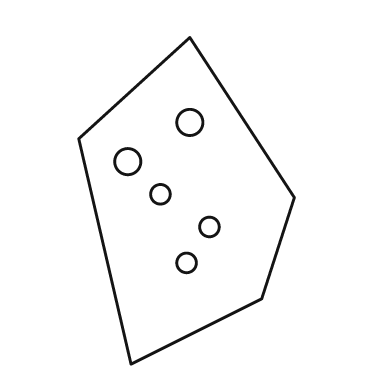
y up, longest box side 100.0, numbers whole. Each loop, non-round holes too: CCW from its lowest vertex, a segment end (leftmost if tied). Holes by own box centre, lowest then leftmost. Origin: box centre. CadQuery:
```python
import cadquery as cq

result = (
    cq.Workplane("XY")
    .moveTo(-17.0, -50.0)
    .lineTo(23.0, -30.0)
    .lineTo(33.0, 1.0)
    .lineTo(1.0, 50.0)
    .lineTo(-33.0, 19.0)
    .close()
    .moveTo(0.0, -19.0)
    .circle(3.0)
    .moveTo(7.0, -8.0)
    .circle(3.0)
    .moveTo(-8.0, 2.0)
    .circle(3.0)
    .moveTo(-18.0, 12.0)
    .circle(4.0)
    .moveTo(1.0, 24.0)
    .circle(4.0)
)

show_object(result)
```